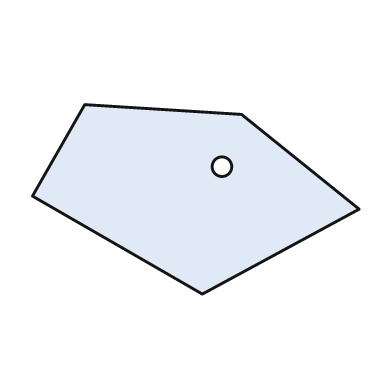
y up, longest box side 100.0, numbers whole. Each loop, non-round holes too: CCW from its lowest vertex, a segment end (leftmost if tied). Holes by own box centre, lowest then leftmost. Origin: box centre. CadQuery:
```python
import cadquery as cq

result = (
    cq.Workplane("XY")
    .moveTo(2.0, -29.0)
    .lineTo(50.0, -3.0)
    .lineTo(14.0, 26.0)
    .lineTo(-34.0, 29.0)
    .lineTo(-50.0, 1.0)
    .close()
    .moveTo(8.0, 10.0)
    .circle(3.0)
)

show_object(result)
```